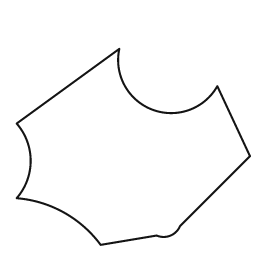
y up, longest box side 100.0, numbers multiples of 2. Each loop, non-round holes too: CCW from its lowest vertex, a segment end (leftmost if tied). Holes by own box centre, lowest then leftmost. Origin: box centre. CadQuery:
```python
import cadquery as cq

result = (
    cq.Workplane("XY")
    .moveTo(-14.0, -42.0)
    .lineTo(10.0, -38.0)
    .threePointArc((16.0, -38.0), (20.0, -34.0))
    .lineTo(50.0, -4.0)
    .lineTo(36.0, 26.0)
    .threePointArc((8.0, 16.0), (-6.0, 42.0))
    .lineTo(-50.0, 10.0)
    .threePointArc((-44.0, -6.0), (-50.0, -22.0))
    .threePointArc((-30.0, -28.0), (-14.0, -42.0))
    .close()
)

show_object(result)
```